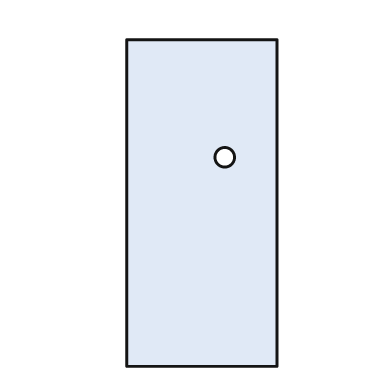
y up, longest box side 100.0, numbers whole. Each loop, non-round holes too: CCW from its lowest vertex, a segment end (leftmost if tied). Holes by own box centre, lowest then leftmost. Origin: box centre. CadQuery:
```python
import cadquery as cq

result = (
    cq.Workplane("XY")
    .moveTo(-23.0, -50.0)
    .lineTo(23.0, -50.0)
    .lineTo(23.0, 50.0)
    .lineTo(-23.0, 50.0)
    .close()
    .moveTo(7.0, 14.0)
    .circle(3.0)
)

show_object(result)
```